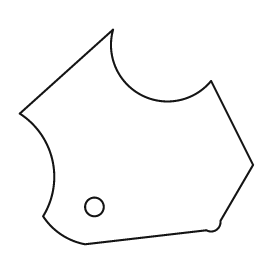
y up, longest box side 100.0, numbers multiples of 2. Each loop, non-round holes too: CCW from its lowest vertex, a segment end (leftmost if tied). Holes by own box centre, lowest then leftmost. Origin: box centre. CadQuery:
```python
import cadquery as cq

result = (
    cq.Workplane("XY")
    .moveTo(-22.0, -46.0)
    .lineTo(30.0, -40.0)
    .threePointArc((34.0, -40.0), (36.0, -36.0))
    .lineTo(50.0, -12.0)
    .lineTo(32.0, 24.0)
    .threePointArc((2.0, 18.0), (-10.0, 46.0))
    .lineTo(-50.0, 10.0)
    .threePointArc((-36.0, -10.0), (-40.0, -34.0))
    .threePointArc((-32.0, -42.0), (-22.0, -46.0))
    .close()
    .moveTo(-18.0, -30.0)
    .circle(4.0)
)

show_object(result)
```